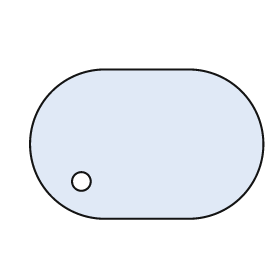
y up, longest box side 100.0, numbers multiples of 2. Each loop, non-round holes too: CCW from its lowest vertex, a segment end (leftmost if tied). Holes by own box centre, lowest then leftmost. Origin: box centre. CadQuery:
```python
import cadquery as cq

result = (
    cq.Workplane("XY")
    .moveTo(-18.0, -32.0)
    .lineTo(18.0, -32.0)
    .threePointArc((50.0, 0.0), (18.0, 32.0))
    .lineTo(-18.0, 32.0)
    .threePointArc((-50.0, 0.0), (-18.0, -32.0))
    .close()
    .moveTo(-28.0, -16.0)
    .circle(4.0)
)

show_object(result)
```